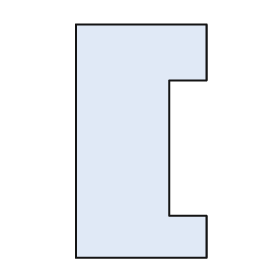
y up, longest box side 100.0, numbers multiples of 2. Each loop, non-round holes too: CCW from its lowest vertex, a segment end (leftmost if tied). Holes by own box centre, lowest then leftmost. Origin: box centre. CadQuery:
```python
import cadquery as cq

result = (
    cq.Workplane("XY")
    .moveTo(-28.0, -50.0)
    .lineTo(28.0, -50.0)
    .lineTo(28.0, -32.0)
    .lineTo(12.0, -32.0)
    .lineTo(12.0, 26.0)
    .lineTo(28.0, 26.0)
    .lineTo(28.0, 50.0)
    .lineTo(-28.0, 50.0)
    .close()
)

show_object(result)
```